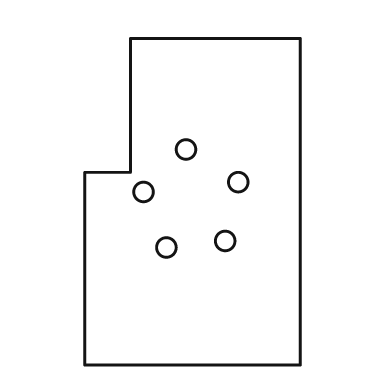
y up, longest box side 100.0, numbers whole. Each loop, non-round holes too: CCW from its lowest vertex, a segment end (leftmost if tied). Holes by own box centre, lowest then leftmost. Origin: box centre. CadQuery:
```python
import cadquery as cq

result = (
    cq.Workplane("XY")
    .moveTo(-33.0, -50.0)
    .lineTo(33.0, -50.0)
    .lineTo(33.0, 50.0)
    .lineTo(-19.0, 50.0)
    .lineTo(-19.0, 9.0)
    .lineTo(-33.0, 9.0)
    .close()
    .moveTo(-8.0, -14.0)
    .circle(3.0)
    .moveTo(10.0, -12.0)
    .circle(3.0)
    .moveTo(-15.0, 3.0)
    .circle(3.0)
    .moveTo(14.0, 6.0)
    .circle(3.0)
    .moveTo(-2.0, 16.0)
    .circle(3.0)
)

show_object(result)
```